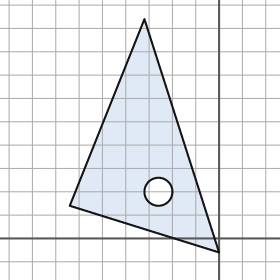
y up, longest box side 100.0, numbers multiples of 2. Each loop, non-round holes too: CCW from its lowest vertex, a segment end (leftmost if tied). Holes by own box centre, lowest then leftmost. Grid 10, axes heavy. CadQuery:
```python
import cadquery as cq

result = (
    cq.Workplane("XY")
    .moveTo(0.0, -6.0)
    .lineTo(-32.0, 94.0)
    .lineTo(-64.0, 14.0)
    .close()
    .moveTo(-26.0, 20.0)
    .circle(6.0)
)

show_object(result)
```